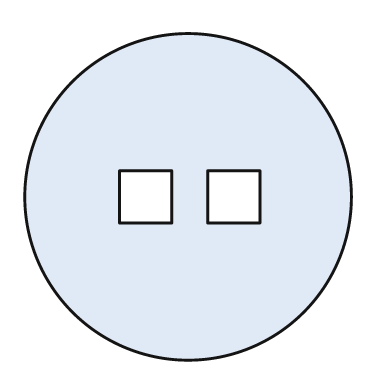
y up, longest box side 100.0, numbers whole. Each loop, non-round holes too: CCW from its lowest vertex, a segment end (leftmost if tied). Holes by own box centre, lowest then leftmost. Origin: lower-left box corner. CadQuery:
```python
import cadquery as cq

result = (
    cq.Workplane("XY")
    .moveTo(50.0, 50.0)
    .circle(50.0)
    .moveTo(29.0, 42.0)
    .lineTo(45.0, 42.0)
    .lineTo(45.0, 58.0)
    .lineTo(29.0, 58.0)
    .close()
    .moveTo(56.0, 42.0)
    .lineTo(72.0, 42.0)
    .lineTo(72.0, 58.0)
    .lineTo(56.0, 58.0)
    .close()
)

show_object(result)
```